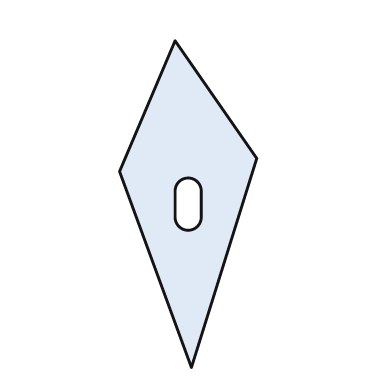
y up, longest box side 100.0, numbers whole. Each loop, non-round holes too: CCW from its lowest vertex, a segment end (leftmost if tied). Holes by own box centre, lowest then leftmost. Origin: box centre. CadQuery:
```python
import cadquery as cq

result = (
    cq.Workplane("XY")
    .moveTo(1.0, -50.0)
    .lineTo(21.0, 14.0)
    .lineTo(-4.0, 50.0)
    .lineTo(-21.0, 10.0)
    .close()
    .moveTo(-4.0, -4.0)
    .threePointArc((0.0, -8.0), (4.0, -4.0))
    .lineTo(4.0, 4.0)
    .threePointArc((0.0, 8.0), (-4.0, 4.0))
    .close()
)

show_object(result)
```